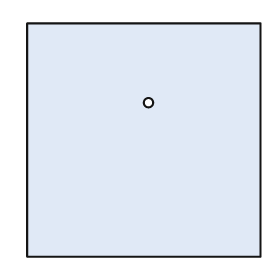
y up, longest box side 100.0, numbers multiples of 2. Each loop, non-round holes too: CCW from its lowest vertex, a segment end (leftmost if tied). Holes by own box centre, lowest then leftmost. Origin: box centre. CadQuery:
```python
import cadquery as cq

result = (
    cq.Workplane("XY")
    .moveTo(-50.0, -50.0)
    .lineTo(50.0, -50.0)
    .lineTo(50.0, 50.0)
    .lineTo(-50.0, 50.0)
    .close()
    .moveTo(2.0, 16.0)
    .circle(2.0)
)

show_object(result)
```